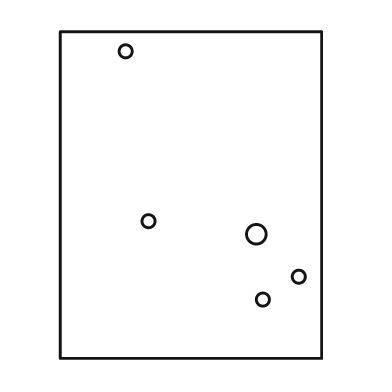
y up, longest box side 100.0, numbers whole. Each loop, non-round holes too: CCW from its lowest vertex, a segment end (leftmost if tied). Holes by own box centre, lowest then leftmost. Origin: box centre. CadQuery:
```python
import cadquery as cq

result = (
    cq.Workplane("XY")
    .moveTo(-40.0, -50.0)
    .lineTo(40.0, -50.0)
    .lineTo(40.0, 50.0)
    .lineTo(-40.0, 50.0)
    .close()
    .moveTo(22.0, -32.0)
    .circle(2.0)
    .moveTo(33.0, -25.0)
    .circle(2.0)
    .moveTo(20.0, -12.0)
    .circle(3.0)
    .moveTo(-13.0, -8.0)
    .circle(2.0)
    .moveTo(-20.0, 44.0)
    .circle(2.0)
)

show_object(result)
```